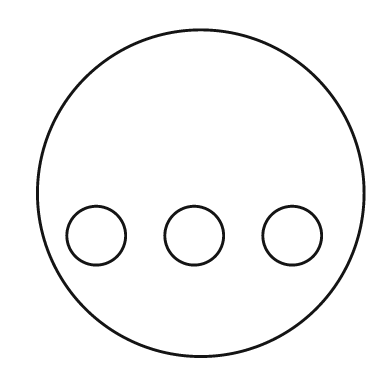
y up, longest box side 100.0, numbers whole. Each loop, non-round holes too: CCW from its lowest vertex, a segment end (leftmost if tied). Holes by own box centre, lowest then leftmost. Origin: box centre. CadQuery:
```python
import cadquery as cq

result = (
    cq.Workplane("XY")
    .moveTo(0.0, 0.0)
    .circle(50.0)
    .moveTo(-32.0, -13.0)
    .circle(9.0)
    .moveTo(-2.0, -13.0)
    .circle(9.0)
    .moveTo(28.0, -13.0)
    .circle(9.0)
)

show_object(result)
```